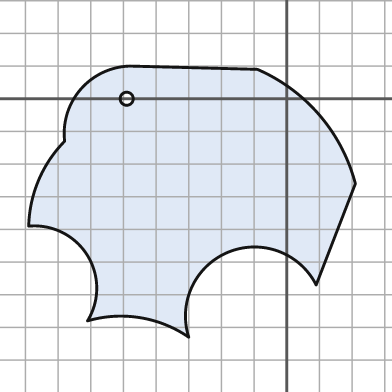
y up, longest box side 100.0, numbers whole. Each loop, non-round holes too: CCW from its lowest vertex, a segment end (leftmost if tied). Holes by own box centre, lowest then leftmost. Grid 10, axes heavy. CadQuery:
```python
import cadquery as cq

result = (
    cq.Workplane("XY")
    .moveTo(-30.0, -73.0)
    .threePointArc((-18.0, -47.0), (9.0, -57.0))
    .lineTo(21.0, -26.0)
    .threePointArc((10.0, -5.0), (-9.0, 9.0))
    .lineTo(-48.0, 10.0)
    .threePointArc((-63.0, 3.0), (-68.0, -13.0))
    .threePointArc((-76.0, -25.0), (-79.0, -39.0))
    .threePointArc((-61.0, -48.0), (-61.0, -68.0))
    .threePointArc((-45.0, -67.0), (-30.0, -73.0))
    .close()
    .moveTo(-49.0, 0.0)
    .circle(2.0)
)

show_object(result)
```